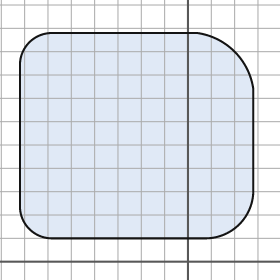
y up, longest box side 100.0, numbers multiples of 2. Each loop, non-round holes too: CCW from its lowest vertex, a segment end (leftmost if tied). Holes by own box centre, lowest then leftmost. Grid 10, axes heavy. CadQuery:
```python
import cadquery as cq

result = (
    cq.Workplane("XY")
    .moveTo(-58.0, 10.0)
    .lineTo(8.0, 10.0)
    .threePointArc((22.0, 16.0), (28.0, 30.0))
    .lineTo(28.0, 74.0)
    .threePointArc((20.0, 90.0), (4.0, 98.0))
    .lineTo(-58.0, 98.0)
    .threePointArc((-68.0, 94.0), (-72.0, 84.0))
    .lineTo(-72.0, 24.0)
    .threePointArc((-68.0, 14.0), (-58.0, 10.0))
    .close()
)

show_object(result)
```